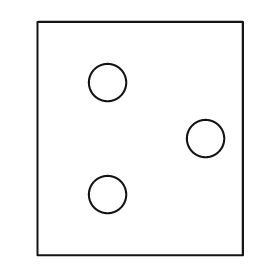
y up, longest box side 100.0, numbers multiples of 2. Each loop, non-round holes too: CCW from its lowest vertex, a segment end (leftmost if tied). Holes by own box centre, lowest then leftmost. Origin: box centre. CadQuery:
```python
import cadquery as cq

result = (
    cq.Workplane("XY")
    .moveTo(-44.0, -50.0)
    .lineTo(44.0, -50.0)
    .lineTo(44.0, 50.0)
    .lineTo(-44.0, 50.0)
    .close()
    .moveTo(-14.0, -24.0)
    .circle(8.0)
    .moveTo(28.0, 0.0)
    .circle(8.0)
    .moveTo(-14.0, 24.0)
    .circle(8.0)
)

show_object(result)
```